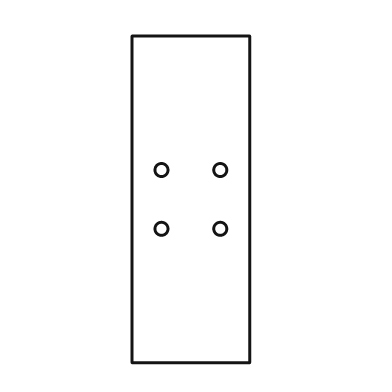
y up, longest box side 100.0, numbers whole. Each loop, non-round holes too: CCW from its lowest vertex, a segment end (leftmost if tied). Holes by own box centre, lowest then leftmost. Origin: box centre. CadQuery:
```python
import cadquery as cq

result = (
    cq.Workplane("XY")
    .moveTo(-18.0, -50.0)
    .lineTo(18.0, -50.0)
    .lineTo(18.0, 50.0)
    .lineTo(-18.0, 50.0)
    .close()
    .moveTo(-9.0, -9.0)
    .circle(2.0)
    .moveTo(9.0, -9.0)
    .circle(2.0)
    .moveTo(-9.0, 9.0)
    .circle(2.0)
    .moveTo(9.0, 9.0)
    .circle(2.0)
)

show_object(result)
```